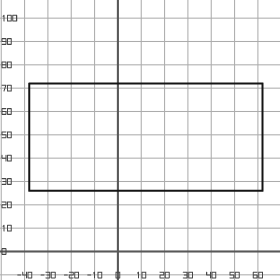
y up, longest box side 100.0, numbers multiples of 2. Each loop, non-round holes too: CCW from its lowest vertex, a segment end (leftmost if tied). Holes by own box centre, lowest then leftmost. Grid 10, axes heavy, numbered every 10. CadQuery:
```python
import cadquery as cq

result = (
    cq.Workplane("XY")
    .moveTo(-38.0, 26.0)
    .lineTo(62.0, 26.0)
    .lineTo(62.0, 72.0)
    .lineTo(-38.0, 72.0)
    .close()
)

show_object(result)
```